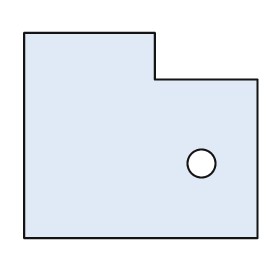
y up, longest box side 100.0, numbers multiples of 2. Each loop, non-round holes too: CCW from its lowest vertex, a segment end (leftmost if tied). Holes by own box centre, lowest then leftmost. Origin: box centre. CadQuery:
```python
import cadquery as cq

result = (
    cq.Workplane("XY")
    .moveTo(-50.0, -44.0)
    .lineTo(50.0, -44.0)
    .lineTo(50.0, 24.0)
    .lineTo(6.0, 24.0)
    .lineTo(6.0, 44.0)
    .lineTo(-50.0, 44.0)
    .close()
    .moveTo(26.0, -12.0)
    .circle(6.0)
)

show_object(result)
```